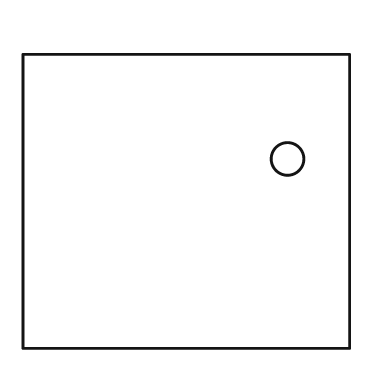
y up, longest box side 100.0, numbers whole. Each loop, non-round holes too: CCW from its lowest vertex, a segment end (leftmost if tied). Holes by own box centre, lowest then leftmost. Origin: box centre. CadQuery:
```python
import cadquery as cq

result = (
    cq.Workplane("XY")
    .moveTo(-50.0, -45.0)
    .lineTo(50.0, -45.0)
    .lineTo(50.0, 45.0)
    .lineTo(-50.0, 45.0)
    .close()
    .moveTo(31.0, 13.0)
    .circle(5.0)
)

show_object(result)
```